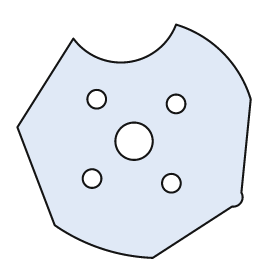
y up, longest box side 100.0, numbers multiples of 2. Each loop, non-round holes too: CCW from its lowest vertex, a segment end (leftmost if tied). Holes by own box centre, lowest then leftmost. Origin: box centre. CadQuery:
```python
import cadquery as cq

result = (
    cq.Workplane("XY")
    .moveTo(8.0, -50.0)
    .lineTo(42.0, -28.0)
    .threePointArc((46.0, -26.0), (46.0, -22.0))
    .lineTo(50.0, 18.0)
    .threePointArc((38.0, 38.0), (18.0, 50.0))
    .threePointArc((-2.0, 34.0), (-26.0, 44.0))
    .lineTo(-50.0, 6.0)
    .lineTo(-34.0, -36.0)
    .threePointArc((-14.0, -46.0), (8.0, -50.0))
    .close()
    .moveTo(16.0, -18.0)
    .circle(4.0)
    .moveTo(-18.0, -16.0)
    .circle(4.0)
    .moveTo(0.0, 0.0)
    .circle(8.0)
    .moveTo(18.0, 16.0)
    .circle(4.0)
    .moveTo(-16.0, 18.0)
    .circle(4.0)
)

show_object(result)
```